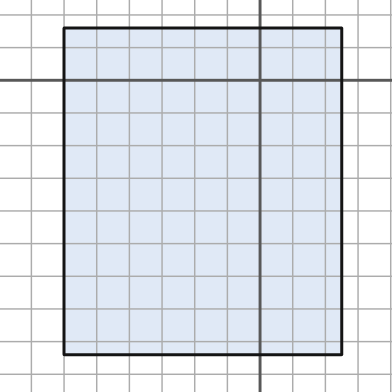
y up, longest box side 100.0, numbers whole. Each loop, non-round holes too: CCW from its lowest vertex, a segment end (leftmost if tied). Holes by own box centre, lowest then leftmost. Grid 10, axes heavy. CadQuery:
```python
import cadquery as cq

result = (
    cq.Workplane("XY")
    .moveTo(-60.0, -84.0)
    .lineTo(25.0, -84.0)
    .lineTo(25.0, 16.0)
    .lineTo(-60.0, 16.0)
    .close()
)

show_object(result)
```